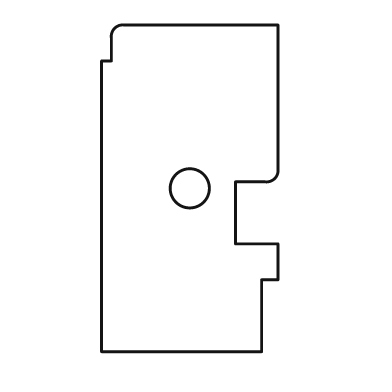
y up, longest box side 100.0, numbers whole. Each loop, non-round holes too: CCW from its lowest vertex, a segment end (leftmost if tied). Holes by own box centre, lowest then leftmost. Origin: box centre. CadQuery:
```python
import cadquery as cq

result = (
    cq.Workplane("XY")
    .moveTo(-27.0, -50.0)
    .lineTo(22.0, -50.0)
    .lineTo(22.0, -28.0)
    .lineTo(27.0, -28.0)
    .lineTo(27.0, -17.0)
    .lineTo(14.0, -17.0)
    .lineTo(14.0, 2.0)
    .lineTo(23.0, 2.0)
    .threePointArc((26.0, 3.0), (27.0, 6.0))
    .lineTo(27.0, 50.0)
    .lineTo(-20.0, 50.0)
    .threePointArc((-23.0, 49.0), (-24.0, 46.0))
    .lineTo(-24.0, 39.0)
    .lineTo(-27.0, 39.0)
    .close()
    .moveTo(0.0, 0.0)
    .circle(6.0)
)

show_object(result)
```